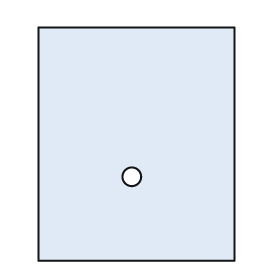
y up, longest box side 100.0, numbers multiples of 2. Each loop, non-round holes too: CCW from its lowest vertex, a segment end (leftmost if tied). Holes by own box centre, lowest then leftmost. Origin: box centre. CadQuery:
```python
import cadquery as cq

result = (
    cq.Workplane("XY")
    .moveTo(-42.0, -50.0)
    .lineTo(42.0, -50.0)
    .lineTo(42.0, 50.0)
    .lineTo(-42.0, 50.0)
    .close()
    .moveTo(-2.0, -14.0)
    .circle(4.0)
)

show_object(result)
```